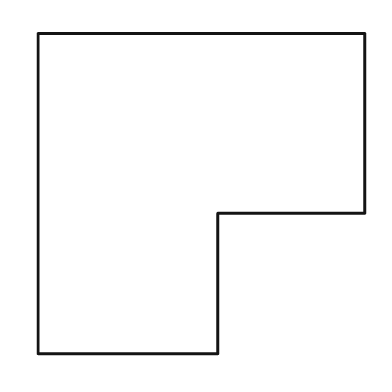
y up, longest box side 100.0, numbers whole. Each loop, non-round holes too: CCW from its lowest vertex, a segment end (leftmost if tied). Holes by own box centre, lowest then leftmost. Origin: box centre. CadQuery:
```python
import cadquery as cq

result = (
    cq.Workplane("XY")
    .moveTo(-50.0, -49.0)
    .lineTo(5.0, -49.0)
    .lineTo(5.0, -6.0)
    .lineTo(50.0, -6.0)
    .lineTo(50.0, 49.0)
    .lineTo(-50.0, 49.0)
    .close()
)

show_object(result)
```